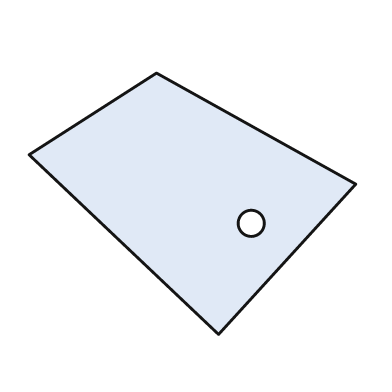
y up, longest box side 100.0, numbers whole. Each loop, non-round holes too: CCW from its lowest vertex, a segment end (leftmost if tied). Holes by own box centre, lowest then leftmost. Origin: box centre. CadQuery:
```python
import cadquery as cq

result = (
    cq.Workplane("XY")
    .moveTo(8.0, -40.0)
    .lineTo(50.0, 6.0)
    .lineTo(-11.0, 40.0)
    .lineTo(-50.0, 15.0)
    .close()
    .moveTo(18.0, -6.0)
    .circle(4.0)
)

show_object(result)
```